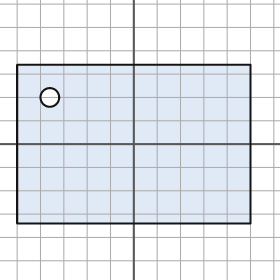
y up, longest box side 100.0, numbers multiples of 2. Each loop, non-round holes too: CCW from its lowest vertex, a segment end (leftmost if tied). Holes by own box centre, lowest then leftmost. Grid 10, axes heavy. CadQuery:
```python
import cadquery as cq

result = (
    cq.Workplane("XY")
    .moveTo(-50.0, -34.0)
    .lineTo(50.0, -34.0)
    .lineTo(50.0, 34.0)
    .lineTo(-50.0, 34.0)
    .close()
    .moveTo(-36.0, 20.0)
    .circle(4.0)
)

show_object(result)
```